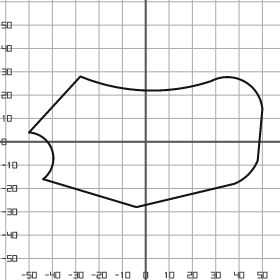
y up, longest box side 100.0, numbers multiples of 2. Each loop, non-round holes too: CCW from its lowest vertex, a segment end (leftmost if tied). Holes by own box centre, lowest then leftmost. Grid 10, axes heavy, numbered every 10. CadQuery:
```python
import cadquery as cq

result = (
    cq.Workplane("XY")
    .moveTo(-4.0, -28.0)
    .lineTo(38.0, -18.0)
    .threePointArc((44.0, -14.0), (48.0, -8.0))
    .lineTo(50.0, 14.0)
    .threePointArc((42.0, 26.0), (28.0, 26.0))
    .threePointArc((0.0, 22.0), (-28.0, 28.0))
    .lineTo(-50.0, 4.0)
    .threePointArc((-40.0, -4.0), (-44.0, -16.0))
    .close()
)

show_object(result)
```